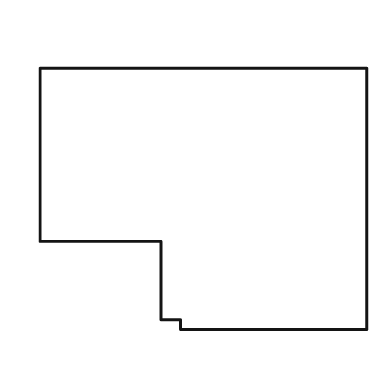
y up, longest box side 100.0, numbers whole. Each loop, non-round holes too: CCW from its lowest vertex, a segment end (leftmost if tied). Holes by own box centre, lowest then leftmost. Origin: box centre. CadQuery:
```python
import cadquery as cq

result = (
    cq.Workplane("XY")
    .moveTo(-7.0, -40.0)
    .lineTo(50.0, -40.0)
    .lineTo(50.0, 40.0)
    .lineTo(-50.0, 40.0)
    .lineTo(-50.0, -13.0)
    .lineTo(-13.0, -13.0)
    .lineTo(-13.0, -37.0)
    .lineTo(-7.0, -37.0)
    .close()
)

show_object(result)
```